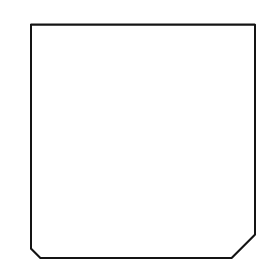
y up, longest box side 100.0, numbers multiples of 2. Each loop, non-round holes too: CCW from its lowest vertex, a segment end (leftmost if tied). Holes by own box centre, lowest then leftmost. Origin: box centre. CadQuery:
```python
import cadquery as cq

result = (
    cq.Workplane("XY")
    .moveTo(-44.0, -50.0)
    .lineTo(38.0, -50.0)
    .lineTo(48.0, -40.0)
    .lineTo(48.0, 50.0)
    .lineTo(-48.0, 50.0)
    .lineTo(-48.0, -46.0)
    .close()
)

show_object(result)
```